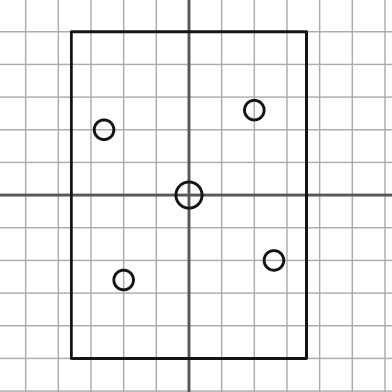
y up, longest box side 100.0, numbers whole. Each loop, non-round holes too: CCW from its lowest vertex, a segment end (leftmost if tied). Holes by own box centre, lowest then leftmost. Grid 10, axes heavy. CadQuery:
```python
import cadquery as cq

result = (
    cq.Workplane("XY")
    .moveTo(-36.0, -50.0)
    .lineTo(36.0, -50.0)
    .lineTo(36.0, 50.0)
    .lineTo(-36.0, 50.0)
    .close()
    .moveTo(-20.0, -26.0)
    .circle(3.0)
    .moveTo(26.0, -20.0)
    .circle(3.0)
    .moveTo(0.0, 0.0)
    .circle(4.0)
    .moveTo(-26.0, 20.0)
    .circle(3.0)
    .moveTo(20.0, 26.0)
    .circle(3.0)
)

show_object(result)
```